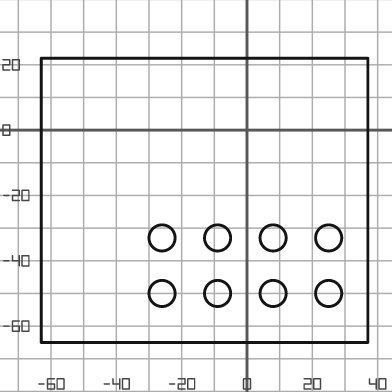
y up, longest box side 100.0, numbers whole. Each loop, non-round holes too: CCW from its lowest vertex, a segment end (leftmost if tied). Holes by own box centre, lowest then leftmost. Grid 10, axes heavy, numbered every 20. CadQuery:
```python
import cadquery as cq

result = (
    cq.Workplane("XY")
    .moveTo(-63.0, -65.0)
    .lineTo(37.0, -65.0)
    .lineTo(37.0, 22.0)
    .lineTo(-63.0, 22.0)
    .close()
    .moveTo(-26.0, -50.0)
    .circle(4.0)
    .moveTo(-9.0, -50.0)
    .circle(4.0)
    .moveTo(8.0, -50.0)
    .circle(4.0)
    .moveTo(25.0, -50.0)
    .circle(4.0)
    .moveTo(-26.0, -33.0)
    .circle(4.0)
    .moveTo(-9.0, -33.0)
    .circle(4.0)
    .moveTo(8.0, -33.0)
    .circle(4.0)
    .moveTo(25.0, -33.0)
    .circle(4.0)
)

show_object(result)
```